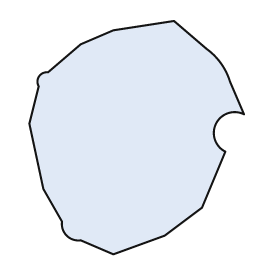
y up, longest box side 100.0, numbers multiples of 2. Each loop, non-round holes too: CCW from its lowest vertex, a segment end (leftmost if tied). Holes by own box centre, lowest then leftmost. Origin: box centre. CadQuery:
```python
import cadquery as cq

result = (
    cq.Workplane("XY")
    .moveTo(-10.0, -50.0)
    .lineTo(12.0, -42.0)
    .lineTo(28.0, -30.0)
    .lineTo(38.0, -6.0)
    .threePointArc((34.0, 6.0), (46.0, 10.0))
    .lineTo(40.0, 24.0)
    .threePointArc((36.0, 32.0), (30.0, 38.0))
    .lineTo(16.0, 50.0)
    .lineTo(-10.0, 46.0)
    .lineTo(-24.0, 40.0)
    .lineTo(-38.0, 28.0)
    .threePointArc((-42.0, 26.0), (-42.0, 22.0))
    .lineTo(-46.0, 6.0)
    .lineTo(-40.0, -22.0)
    .lineTo(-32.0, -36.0)
    .threePointArc((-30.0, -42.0), (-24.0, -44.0))
    .close()
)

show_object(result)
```